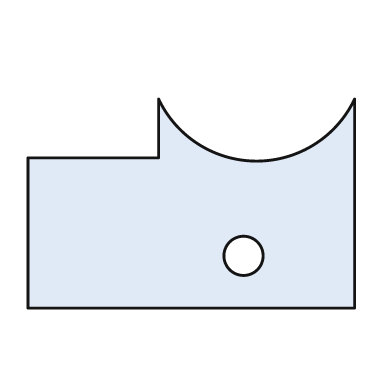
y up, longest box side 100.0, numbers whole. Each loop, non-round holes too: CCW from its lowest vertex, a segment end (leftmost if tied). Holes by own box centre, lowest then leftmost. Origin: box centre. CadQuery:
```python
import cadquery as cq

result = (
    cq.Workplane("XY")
    .moveTo(-50.0, -32.0)
    .lineTo(50.0, -32.0)
    .lineTo(50.0, 32.0)
    .threePointArc((20.0, 13.0), (-10.0, 32.0))
    .lineTo(-10.0, 14.0)
    .lineTo(-50.0, 14.0)
    .close()
    .moveTo(16.0, -16.0)
    .circle(6.0)
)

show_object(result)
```